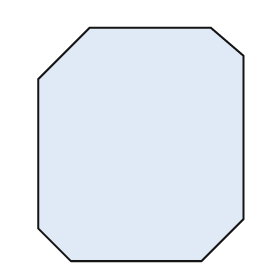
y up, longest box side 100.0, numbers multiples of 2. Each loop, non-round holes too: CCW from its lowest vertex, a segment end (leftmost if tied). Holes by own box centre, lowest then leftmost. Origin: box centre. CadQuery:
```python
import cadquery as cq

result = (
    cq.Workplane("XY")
    .moveTo(-30.0, -50.0)
    .lineTo(26.0, -50.0)
    .lineTo(44.0, -32.0)
    .lineTo(44.0, 38.0)
    .lineTo(30.0, 50.0)
    .lineTo(-22.0, 50.0)
    .lineTo(-44.0, 28.0)
    .lineTo(-44.0, -36.0)
    .close()
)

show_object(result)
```